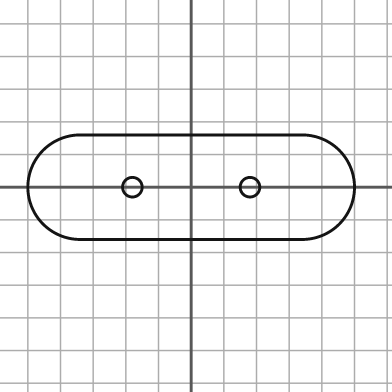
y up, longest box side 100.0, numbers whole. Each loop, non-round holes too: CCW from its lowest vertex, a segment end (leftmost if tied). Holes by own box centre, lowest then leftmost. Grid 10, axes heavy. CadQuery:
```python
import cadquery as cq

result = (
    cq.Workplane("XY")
    .moveTo(-34.0, -16.0)
    .lineTo(34.0, -16.0)
    .threePointArc((50.0, 0.0), (34.0, 16.0))
    .lineTo(-34.0, 16.0)
    .threePointArc((-50.0, 0.0), (-34.0, -16.0))
    .close()
    .moveTo(-18.0, 0.0)
    .circle(3.0)
    .moveTo(18.0, 0.0)
    .circle(3.0)
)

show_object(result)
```